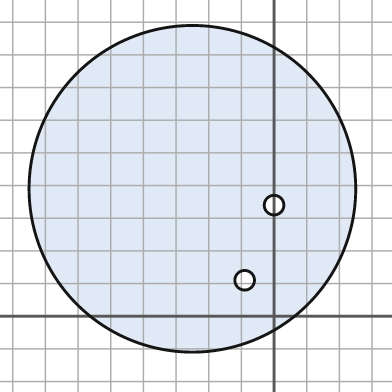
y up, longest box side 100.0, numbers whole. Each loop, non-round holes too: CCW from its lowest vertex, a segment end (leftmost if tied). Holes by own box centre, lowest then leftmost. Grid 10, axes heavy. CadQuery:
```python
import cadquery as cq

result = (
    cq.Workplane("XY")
    .moveTo(-25.0, 39.0)
    .circle(50.0)
    .moveTo(-9.0, 11.0)
    .circle(3.0)
    .moveTo(0.0, 34.0)
    .circle(3.0)
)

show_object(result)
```